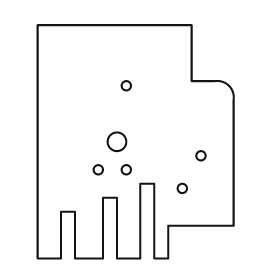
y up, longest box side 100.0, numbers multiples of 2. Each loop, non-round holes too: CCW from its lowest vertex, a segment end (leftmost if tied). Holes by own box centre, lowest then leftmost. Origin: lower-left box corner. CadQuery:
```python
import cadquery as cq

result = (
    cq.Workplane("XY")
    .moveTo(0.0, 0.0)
    .lineTo(10.0, 0.0)
    .lineTo(10.0, 20.0)
    .lineTo(16.0, 20.0)
    .lineTo(16.0, 0.0)
    .lineTo(28.0, 0.0)
    .lineTo(28.0, 26.0)
    .lineTo(34.0, 26.0)
    .lineTo(34.0, 0.0)
    .lineTo(44.0, 0.0)
    .lineTo(44.0, 32.0)
    .lineTo(50.0, 32.0)
    .lineTo(50.0, 0.0)
    .lineTo(56.0, 0.0)
    .lineTo(56.0, 14.0)
    .lineTo(84.0, 14.0)
    .lineTo(84.0, 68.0)
    .threePointArc((82.0, 74.0), (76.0, 76.0))
    .lineTo(66.0, 76.0)
    .lineTo(66.0, 100.0)
    .lineTo(0.0, 100.0)
    .close()
    .moveTo(62.0, 30.0)
    .circle(2.0)
    .moveTo(26.0, 38.0)
    .circle(2.0)
    .moveTo(38.0, 38.0)
    .circle(2.0)
    .moveTo(70.0, 44.0)
    .circle(2.0)
    .moveTo(34.0, 50.0)
    .circle(4.0)
    .moveTo(38.0, 74.0)
    .circle(2.0)
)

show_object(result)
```